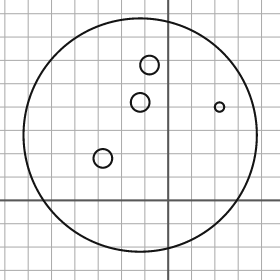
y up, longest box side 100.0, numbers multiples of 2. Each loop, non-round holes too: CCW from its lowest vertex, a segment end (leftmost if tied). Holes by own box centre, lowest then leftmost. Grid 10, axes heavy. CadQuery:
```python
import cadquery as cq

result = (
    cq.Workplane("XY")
    .moveTo(-12.0, 28.0)
    .circle(50.0)
    .moveTo(-28.0, 18.0)
    .circle(4.0)
    .moveTo(22.0, 40.0)
    .circle(2.0)
    .moveTo(-12.0, 42.0)
    .circle(4.0)
    .moveTo(-8.0, 58.0)
    .circle(4.0)
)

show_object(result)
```